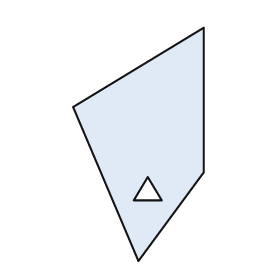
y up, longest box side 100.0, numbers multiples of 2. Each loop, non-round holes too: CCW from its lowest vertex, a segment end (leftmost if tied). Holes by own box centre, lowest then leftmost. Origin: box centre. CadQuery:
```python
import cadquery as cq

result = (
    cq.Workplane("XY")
    .moveTo(0.0, -50.0)
    .lineTo(28.0, -12.0)
    .lineTo(28.0, 50.0)
    .lineTo(-28.0, 16.0)
    .close()
    .moveTo(-2.0, -24.0)
    .lineTo(10.0, -24.0)
    .lineTo(4.0, -14.0)
    .close()
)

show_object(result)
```